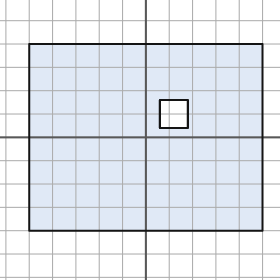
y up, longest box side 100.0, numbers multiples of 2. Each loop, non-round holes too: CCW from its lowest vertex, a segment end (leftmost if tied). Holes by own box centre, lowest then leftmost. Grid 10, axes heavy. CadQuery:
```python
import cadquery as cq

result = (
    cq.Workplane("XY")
    .moveTo(-50.0, -40.0)
    .lineTo(50.0, -40.0)
    .lineTo(50.0, 40.0)
    .lineTo(-50.0, 40.0)
    .close()
    .moveTo(6.0, 4.0)
    .lineTo(18.0, 4.0)
    .lineTo(18.0, 16.0)
    .lineTo(6.0, 16.0)
    .close()
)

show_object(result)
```